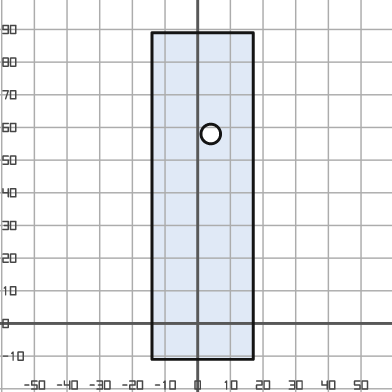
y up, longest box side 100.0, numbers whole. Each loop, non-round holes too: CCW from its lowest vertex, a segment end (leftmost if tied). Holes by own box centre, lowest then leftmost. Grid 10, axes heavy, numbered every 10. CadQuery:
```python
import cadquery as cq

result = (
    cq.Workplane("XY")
    .moveTo(-14.0, -11.0)
    .lineTo(17.0, -11.0)
    .lineTo(17.0, 89.0)
    .lineTo(-14.0, 89.0)
    .close()
    .moveTo(4.0, 58.0)
    .circle(3.0)
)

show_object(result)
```